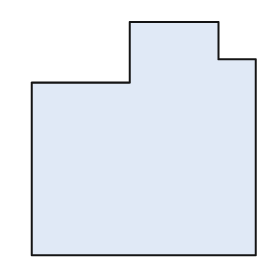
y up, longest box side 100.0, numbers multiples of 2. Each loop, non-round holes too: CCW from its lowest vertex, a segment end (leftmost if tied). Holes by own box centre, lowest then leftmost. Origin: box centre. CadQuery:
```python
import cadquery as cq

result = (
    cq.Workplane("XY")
    .moveTo(-48.0, -50.0)
    .lineTo(48.0, -50.0)
    .lineTo(48.0, 34.0)
    .lineTo(32.0, 34.0)
    .lineTo(32.0, 50.0)
    .lineTo(-6.0, 50.0)
    .lineTo(-6.0, 24.0)
    .lineTo(-48.0, 24.0)
    .close()
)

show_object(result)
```